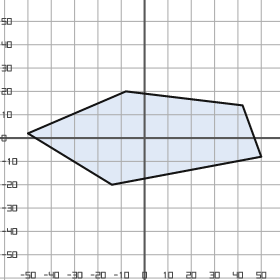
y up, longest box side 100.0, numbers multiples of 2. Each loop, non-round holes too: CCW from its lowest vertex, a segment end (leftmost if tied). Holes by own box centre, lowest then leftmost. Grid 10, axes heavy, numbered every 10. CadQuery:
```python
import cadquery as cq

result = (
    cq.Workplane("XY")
    .moveTo(-14.0, -20.0)
    .lineTo(50.0, -8.0)
    .lineTo(42.0, 14.0)
    .lineTo(-8.0, 20.0)
    .lineTo(-50.0, 2.0)
    .close()
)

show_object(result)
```